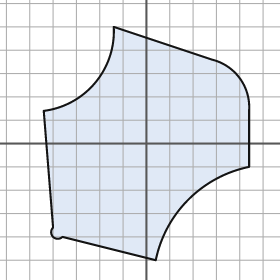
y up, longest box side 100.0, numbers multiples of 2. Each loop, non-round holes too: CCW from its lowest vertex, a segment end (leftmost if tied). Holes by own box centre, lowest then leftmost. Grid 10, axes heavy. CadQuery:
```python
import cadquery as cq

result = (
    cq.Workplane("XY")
    .moveTo(4.0, -50.0)
    .threePointArc((18.0, -24.0), (44.0, -10.0))
    .lineTo(44.0, 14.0)
    .threePointArc((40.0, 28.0), (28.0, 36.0))
    .lineTo(-14.0, 50.0)
    .threePointArc((-22.0, 26.0), (-44.0, 14.0))
    .lineTo(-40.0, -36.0)
    .threePointArc((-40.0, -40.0), (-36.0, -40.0))
    .close()
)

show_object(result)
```